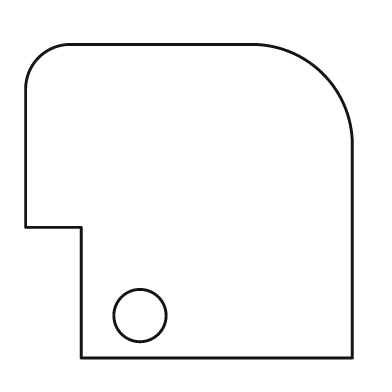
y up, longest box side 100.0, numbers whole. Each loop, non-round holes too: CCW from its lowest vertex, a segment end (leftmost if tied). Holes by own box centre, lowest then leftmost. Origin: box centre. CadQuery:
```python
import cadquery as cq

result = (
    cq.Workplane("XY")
    .moveTo(-33.0, -48.0)
    .lineTo(50.0, -48.0)
    .lineTo(50.0, 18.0)
    .threePointArc((41.0, 39.0), (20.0, 48.0))
    .lineTo(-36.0, 48.0)
    .threePointArc((-46.0, 44.0), (-50.0, 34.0))
    .lineTo(-50.0, -8.0)
    .lineTo(-33.0, -8.0)
    .close()
    .moveTo(-15.0, -35.0)
    .circle(8.0)
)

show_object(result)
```